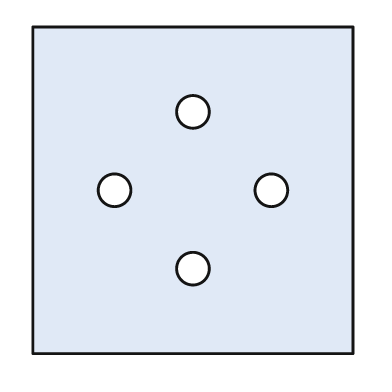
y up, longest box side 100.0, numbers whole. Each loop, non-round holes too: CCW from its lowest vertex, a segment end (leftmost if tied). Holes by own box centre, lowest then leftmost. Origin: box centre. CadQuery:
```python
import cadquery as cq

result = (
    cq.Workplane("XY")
    .moveTo(-49.0, -50.0)
    .lineTo(49.0, -50.0)
    .lineTo(49.0, 50.0)
    .lineTo(-49.0, 50.0)
    .close()
    .moveTo(0.0, -24.0)
    .circle(5.0)
    .moveTo(-24.0, 0.0)
    .circle(5.0)
    .moveTo(24.0, 0.0)
    .circle(5.0)
    .moveTo(0.0, 24.0)
    .circle(5.0)
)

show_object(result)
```